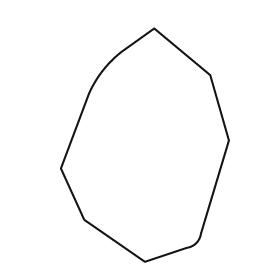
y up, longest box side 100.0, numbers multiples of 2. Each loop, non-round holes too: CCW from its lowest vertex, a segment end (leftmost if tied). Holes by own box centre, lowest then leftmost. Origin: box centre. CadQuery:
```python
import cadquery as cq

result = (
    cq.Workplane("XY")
    .moveTo(0.0, -50.0)
    .lineTo(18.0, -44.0)
    .threePointArc((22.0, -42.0), (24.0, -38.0))
    .lineTo(36.0, 2.0)
    .lineTo(28.0, 30.0)
    .lineTo(4.0, 50.0)
    .lineTo(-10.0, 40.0)
    .threePointArc((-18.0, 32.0), (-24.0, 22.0))
    .lineTo(-36.0, -10.0)
    .lineTo(-26.0, -32.0)
    .close()
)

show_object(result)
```